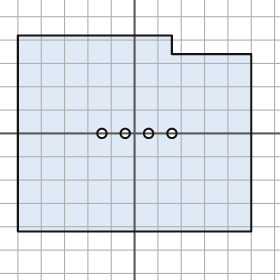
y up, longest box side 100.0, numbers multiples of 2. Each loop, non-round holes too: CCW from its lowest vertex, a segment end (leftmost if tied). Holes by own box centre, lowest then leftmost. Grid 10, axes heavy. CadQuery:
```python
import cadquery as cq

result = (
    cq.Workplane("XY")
    .moveTo(-50.0, -42.0)
    .lineTo(50.0, -42.0)
    .lineTo(50.0, 34.0)
    .lineTo(16.0, 34.0)
    .lineTo(16.0, 42.0)
    .lineTo(-50.0, 42.0)
    .close()
    .moveTo(-14.0, 0.0)
    .circle(2.0)
    .moveTo(-4.0, 0.0)
    .circle(2.0)
    .moveTo(6.0, 0.0)
    .circle(2.0)
    .moveTo(16.0, 0.0)
    .circle(2.0)
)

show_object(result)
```